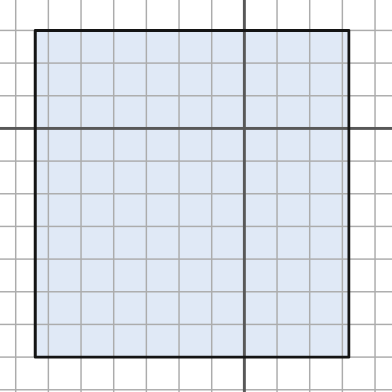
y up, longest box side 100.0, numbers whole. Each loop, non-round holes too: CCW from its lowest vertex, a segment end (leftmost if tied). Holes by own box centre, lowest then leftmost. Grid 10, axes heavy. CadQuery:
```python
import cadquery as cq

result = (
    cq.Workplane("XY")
    .moveTo(-64.0, -70.0)
    .lineTo(32.0, -70.0)
    .lineTo(32.0, 30.0)
    .lineTo(-64.0, 30.0)
    .close()
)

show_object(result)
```